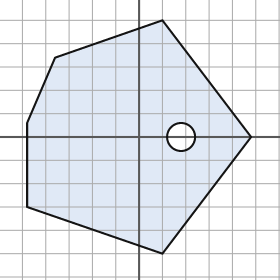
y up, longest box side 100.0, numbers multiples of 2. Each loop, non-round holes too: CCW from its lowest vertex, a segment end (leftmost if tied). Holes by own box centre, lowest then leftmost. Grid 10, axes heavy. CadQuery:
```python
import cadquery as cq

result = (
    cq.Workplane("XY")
    .moveTo(10.0, -50.0)
    .lineTo(48.0, 0.0)
    .lineTo(10.0, 50.0)
    .lineTo(-36.0, 34.0)
    .lineTo(-48.0, 6.0)
    .lineTo(-48.0, -30.0)
    .close()
    .moveTo(18.0, 0.0)
    .circle(6.0)
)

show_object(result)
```